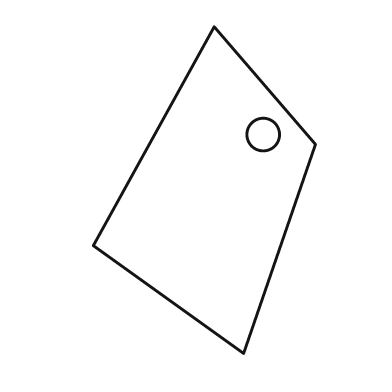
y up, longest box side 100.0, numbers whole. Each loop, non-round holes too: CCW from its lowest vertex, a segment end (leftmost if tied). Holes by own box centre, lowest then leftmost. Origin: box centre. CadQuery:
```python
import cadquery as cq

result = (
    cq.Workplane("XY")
    .moveTo(12.0, -50.0)
    .lineTo(34.0, 14.0)
    .lineTo(3.0, 50.0)
    .lineTo(-34.0, -17.0)
    .close()
    .moveTo(18.0, 17.0)
    .circle(5.0)
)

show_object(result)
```